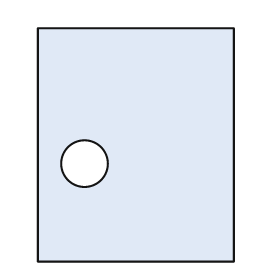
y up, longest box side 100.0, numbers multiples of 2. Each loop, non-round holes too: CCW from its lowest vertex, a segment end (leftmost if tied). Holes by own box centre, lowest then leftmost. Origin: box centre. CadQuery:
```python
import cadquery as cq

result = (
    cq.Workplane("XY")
    .moveTo(-42.0, -50.0)
    .lineTo(42.0, -50.0)
    .lineTo(42.0, 50.0)
    .lineTo(-42.0, 50.0)
    .close()
    .moveTo(-22.0, -8.0)
    .circle(10.0)
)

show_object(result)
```